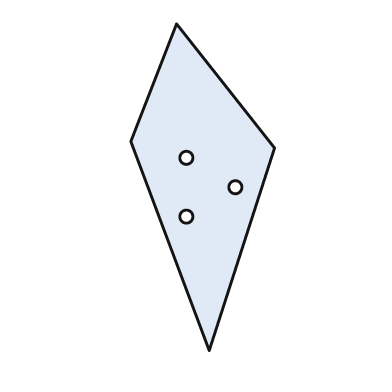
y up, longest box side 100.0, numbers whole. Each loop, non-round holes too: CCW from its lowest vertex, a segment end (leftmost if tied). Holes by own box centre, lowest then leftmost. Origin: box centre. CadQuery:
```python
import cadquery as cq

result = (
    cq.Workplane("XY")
    .moveTo(2.0, -50.0)
    .lineTo(22.0, 12.0)
    .lineTo(-8.0, 50.0)
    .lineTo(-22.0, 14.0)
    .close()
    .moveTo(-5.0, -9.0)
    .circle(2.0)
    .moveTo(10.0, 0.0)
    .circle(2.0)
    .moveTo(-5.0, 9.0)
    .circle(2.0)
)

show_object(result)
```